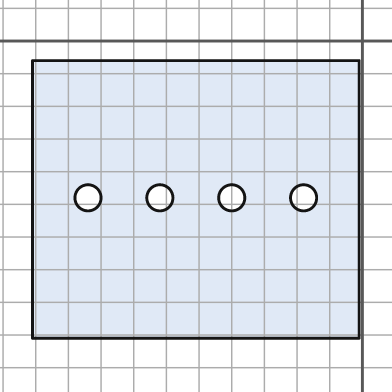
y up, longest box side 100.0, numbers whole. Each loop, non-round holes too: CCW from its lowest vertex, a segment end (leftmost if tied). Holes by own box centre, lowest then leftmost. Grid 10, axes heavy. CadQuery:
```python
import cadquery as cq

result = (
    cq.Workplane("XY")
    .moveTo(-101.0, -91.0)
    .lineTo(-1.0, -91.0)
    .lineTo(-1.0, -6.0)
    .lineTo(-101.0, -6.0)
    .close()
    .moveTo(-84.0, -48.0)
    .circle(4.0)
    .moveTo(-62.0, -48.0)
    .circle(4.0)
    .moveTo(-40.0, -48.0)
    .circle(4.0)
    .moveTo(-18.0, -48.0)
    .circle(4.0)
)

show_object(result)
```